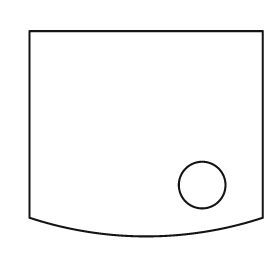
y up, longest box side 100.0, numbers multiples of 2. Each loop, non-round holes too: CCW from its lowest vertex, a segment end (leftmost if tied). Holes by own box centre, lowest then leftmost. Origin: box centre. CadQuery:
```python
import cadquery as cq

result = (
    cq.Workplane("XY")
    .moveTo(-50.0, -36.0)
    .threePointArc((0.0, -44.0), (50.0, -36.0))
    .lineTo(50.0, 44.0)
    .lineTo(-50.0, 44.0)
    .close()
    .moveTo(24.0, -22.0)
    .circle(10.0)
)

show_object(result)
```